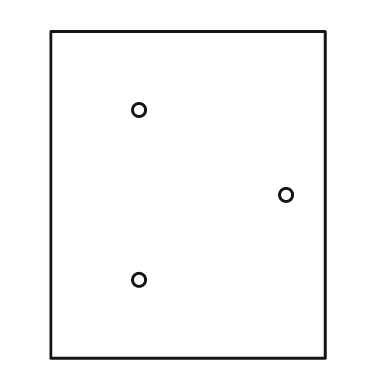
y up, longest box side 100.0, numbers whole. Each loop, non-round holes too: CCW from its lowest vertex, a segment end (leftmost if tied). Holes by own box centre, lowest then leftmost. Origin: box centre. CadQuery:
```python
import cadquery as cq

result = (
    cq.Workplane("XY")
    .moveTo(-42.0, -50.0)
    .lineTo(42.0, -50.0)
    .lineTo(42.0, 50.0)
    .lineTo(-42.0, 50.0)
    .close()
    .moveTo(-15.0, -26.0)
    .circle(2.0)
    .moveTo(30.0, 0.0)
    .circle(2.0)
    .moveTo(-15.0, 26.0)
    .circle(2.0)
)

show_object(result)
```